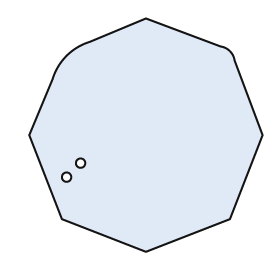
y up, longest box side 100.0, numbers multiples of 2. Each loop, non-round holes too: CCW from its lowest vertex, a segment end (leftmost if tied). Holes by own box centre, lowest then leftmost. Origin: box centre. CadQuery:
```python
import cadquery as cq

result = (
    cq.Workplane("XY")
    .moveTo(0.0, -50.0)
    .lineTo(36.0, -36.0)
    .lineTo(50.0, 0.0)
    .lineTo(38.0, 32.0)
    .threePointArc((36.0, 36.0), (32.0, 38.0))
    .lineTo(0.0, 50.0)
    .lineTo(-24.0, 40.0)
    .threePointArc((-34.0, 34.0), (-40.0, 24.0))
    .lineTo(-50.0, 0.0)
    .lineTo(-36.0, -36.0)
    .close()
    .moveTo(-34.0, -18.0)
    .circle(2.0)
    .moveTo(-28.0, -12.0)
    .circle(2.0)
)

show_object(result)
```